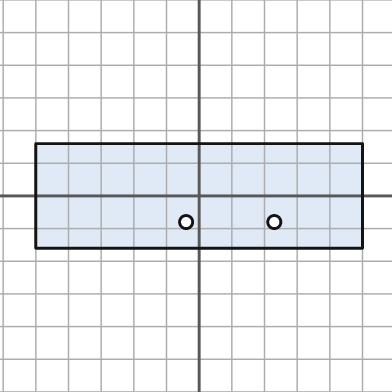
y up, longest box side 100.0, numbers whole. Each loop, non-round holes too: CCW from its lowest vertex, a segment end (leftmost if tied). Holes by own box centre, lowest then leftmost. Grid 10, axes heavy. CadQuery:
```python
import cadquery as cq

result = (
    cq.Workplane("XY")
    .moveTo(-50.0, -16.0)
    .lineTo(50.0, -16.0)
    .lineTo(50.0, 16.0)
    .lineTo(-50.0, 16.0)
    .close()
    .moveTo(-4.0, -8.0)
    .circle(2.0)
    .moveTo(23.0, -8.0)
    .circle(2.0)
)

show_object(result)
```